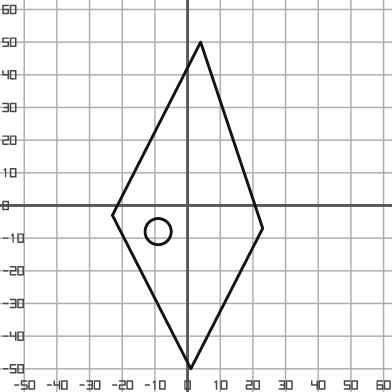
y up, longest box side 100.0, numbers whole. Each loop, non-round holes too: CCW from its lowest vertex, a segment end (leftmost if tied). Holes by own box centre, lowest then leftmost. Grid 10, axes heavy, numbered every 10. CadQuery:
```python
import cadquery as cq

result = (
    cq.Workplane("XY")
    .moveTo(1.0, -50.0)
    .lineTo(23.0, -7.0)
    .lineTo(4.0, 50.0)
    .lineTo(-23.0, -3.0)
    .close()
    .moveTo(-9.0, -8.0)
    .circle(4.0)
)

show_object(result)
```